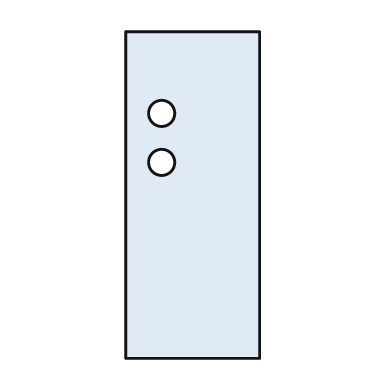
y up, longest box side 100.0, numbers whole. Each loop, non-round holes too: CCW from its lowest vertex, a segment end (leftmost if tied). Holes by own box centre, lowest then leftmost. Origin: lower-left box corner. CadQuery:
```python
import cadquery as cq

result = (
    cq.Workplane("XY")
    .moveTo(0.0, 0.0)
    .lineTo(41.0, 0.0)
    .lineTo(41.0, 100.0)
    .lineTo(0.0, 100.0)
    .close()
    .moveTo(11.0, 60.0)
    .circle(4.0)
    .moveTo(11.0, 75.0)
    .circle(4.0)
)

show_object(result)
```